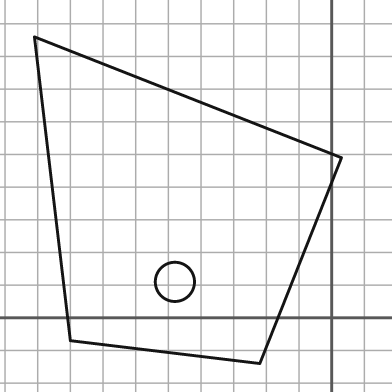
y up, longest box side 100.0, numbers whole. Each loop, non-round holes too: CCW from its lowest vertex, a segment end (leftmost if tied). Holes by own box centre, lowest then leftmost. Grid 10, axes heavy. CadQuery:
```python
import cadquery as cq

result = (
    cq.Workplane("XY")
    .moveTo(-22.0, -14.0)
    .lineTo(3.0, 49.0)
    .lineTo(-91.0, 86.0)
    .lineTo(-80.0, -7.0)
    .close()
    .moveTo(-48.0, 11.0)
    .circle(6.0)
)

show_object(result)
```